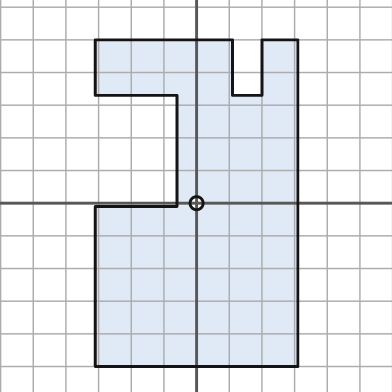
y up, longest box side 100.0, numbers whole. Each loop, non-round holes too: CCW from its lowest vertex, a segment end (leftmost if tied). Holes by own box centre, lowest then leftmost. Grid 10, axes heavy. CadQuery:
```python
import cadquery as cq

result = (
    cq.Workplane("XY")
    .moveTo(-31.0, -50.0)
    .lineTo(31.0, -50.0)
    .lineTo(31.0, 50.0)
    .lineTo(20.0, 50.0)
    .lineTo(20.0, 33.0)
    .lineTo(11.0, 33.0)
    .lineTo(11.0, 50.0)
    .lineTo(-31.0, 50.0)
    .lineTo(-31.0, 33.0)
    .lineTo(-6.0, 33.0)
    .lineTo(-6.0, -1.0)
    .lineTo(-31.0, -1.0)
    .close()
    .moveTo(0.0, 0.0)
    .circle(2.0)
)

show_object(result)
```